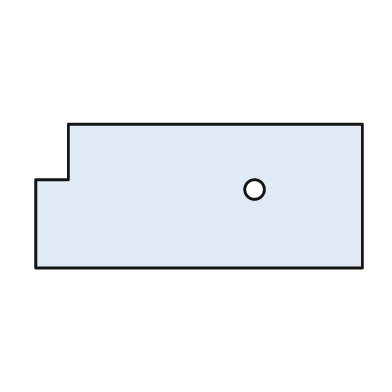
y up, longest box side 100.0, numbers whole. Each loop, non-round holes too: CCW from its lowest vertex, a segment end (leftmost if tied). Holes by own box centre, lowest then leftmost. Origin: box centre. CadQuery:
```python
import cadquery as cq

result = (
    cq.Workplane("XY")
    .moveTo(-50.0, -22.0)
    .lineTo(50.0, -22.0)
    .lineTo(50.0, 22.0)
    .lineTo(-40.0, 22.0)
    .lineTo(-40.0, 5.0)
    .lineTo(-50.0, 5.0)
    .close()
    .moveTo(17.0, 2.0)
    .circle(3.0)
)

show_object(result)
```